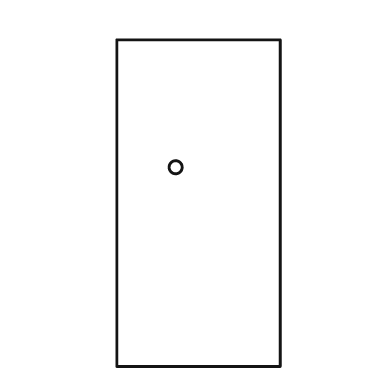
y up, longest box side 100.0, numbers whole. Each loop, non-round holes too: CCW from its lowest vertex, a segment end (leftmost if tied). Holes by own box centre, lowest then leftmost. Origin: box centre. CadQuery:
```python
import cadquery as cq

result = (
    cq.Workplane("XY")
    .moveTo(-25.0, -50.0)
    .lineTo(25.0, -50.0)
    .lineTo(25.0, 50.0)
    .lineTo(-25.0, 50.0)
    .close()
    .moveTo(-7.0, 11.0)
    .circle(2.0)
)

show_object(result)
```